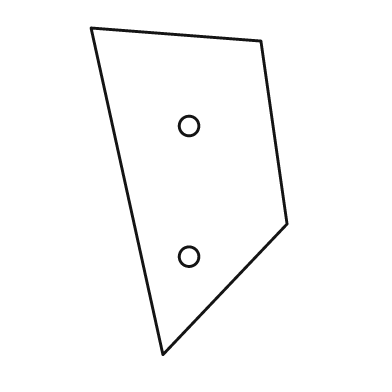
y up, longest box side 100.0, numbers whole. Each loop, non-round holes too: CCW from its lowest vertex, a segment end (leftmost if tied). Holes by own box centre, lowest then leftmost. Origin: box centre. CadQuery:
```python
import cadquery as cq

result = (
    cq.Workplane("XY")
    .moveTo(-8.0, -50.0)
    .lineTo(30.0, -10.0)
    .lineTo(22.0, 46.0)
    .lineTo(-30.0, 50.0)
    .close()
    .moveTo(0.0, -20.0)
    .circle(3.0)
    .moveTo(0.0, 20.0)
    .circle(3.0)
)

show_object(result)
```